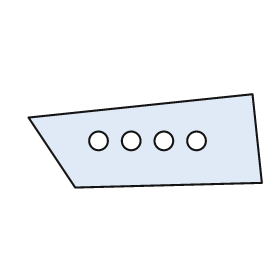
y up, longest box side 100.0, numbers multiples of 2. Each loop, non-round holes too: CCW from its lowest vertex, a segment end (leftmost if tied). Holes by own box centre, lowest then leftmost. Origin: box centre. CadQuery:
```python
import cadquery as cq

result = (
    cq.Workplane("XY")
    .moveTo(-30.0, -20.0)
    .lineTo(50.0, -18.0)
    .lineTo(46.0, 20.0)
    .lineTo(-50.0, 10.0)
    .close()
    .moveTo(-20.0, 0.0)
    .circle(4.0)
    .moveTo(-6.0, 0.0)
    .circle(4.0)
    .moveTo(8.0, 0.0)
    .circle(4.0)
    .moveTo(22.0, 0.0)
    .circle(4.0)
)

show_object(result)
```